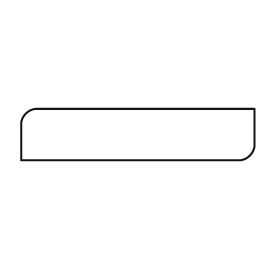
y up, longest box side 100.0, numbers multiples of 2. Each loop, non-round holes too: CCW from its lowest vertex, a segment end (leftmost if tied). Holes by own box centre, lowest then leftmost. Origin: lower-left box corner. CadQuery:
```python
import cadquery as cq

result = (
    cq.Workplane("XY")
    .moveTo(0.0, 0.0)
    .lineTo(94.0, 0.0)
    .threePointArc((98.0, 2.0), (100.0, 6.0))
    .lineTo(100.0, 22.0)
    .lineTo(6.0, 22.0)
    .threePointArc((2.0, 20.0), (0.0, 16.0))
    .close()
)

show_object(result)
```